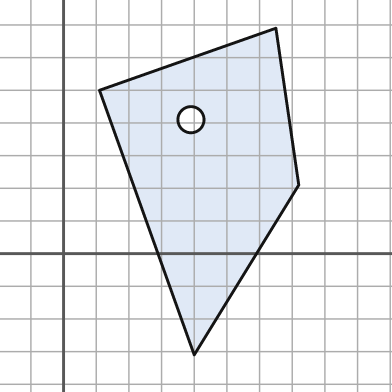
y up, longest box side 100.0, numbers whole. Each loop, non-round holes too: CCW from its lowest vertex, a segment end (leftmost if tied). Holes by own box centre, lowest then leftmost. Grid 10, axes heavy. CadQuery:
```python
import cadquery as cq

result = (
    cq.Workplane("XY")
    .moveTo(40.0, -31.0)
    .lineTo(72.0, 21.0)
    .lineTo(65.0, 69.0)
    .lineTo(11.0, 50.0)
    .close()
    .moveTo(39.0, 41.0)
    .circle(4.0)
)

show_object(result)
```